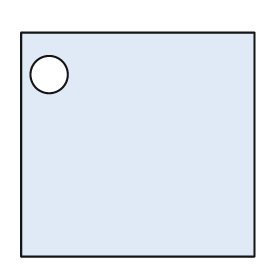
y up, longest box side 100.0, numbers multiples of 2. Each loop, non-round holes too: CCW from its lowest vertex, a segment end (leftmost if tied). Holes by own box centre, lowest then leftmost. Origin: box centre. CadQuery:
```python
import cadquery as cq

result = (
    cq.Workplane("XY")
    .moveTo(-50.0, -48.0)
    .lineTo(50.0, -48.0)
    .lineTo(50.0, 48.0)
    .lineTo(-50.0, 48.0)
    .close()
    .moveTo(-38.0, 30.0)
    .circle(8.0)
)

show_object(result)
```